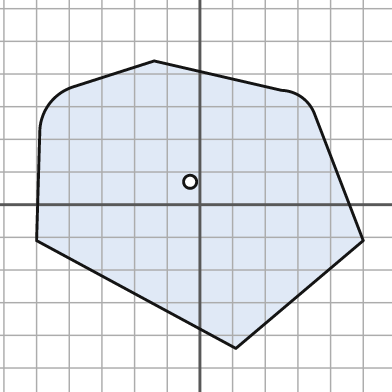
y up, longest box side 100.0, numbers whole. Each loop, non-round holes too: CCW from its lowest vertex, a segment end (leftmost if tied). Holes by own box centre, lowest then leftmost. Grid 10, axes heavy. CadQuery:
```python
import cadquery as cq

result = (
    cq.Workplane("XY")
    .moveTo(11.0, -44.0)
    .lineTo(50.0, -11.0)
    .lineTo(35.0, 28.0)
    .threePointArc((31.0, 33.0), (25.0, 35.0))
    .lineTo(-14.0, 44.0)
    .lineTo(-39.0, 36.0)
    .threePointArc((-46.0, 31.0), (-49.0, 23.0))
    .lineTo(-50.0, -11.0)
    .close()
    .moveTo(-3.0, 7.0)
    .circle(2.0)
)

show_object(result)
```